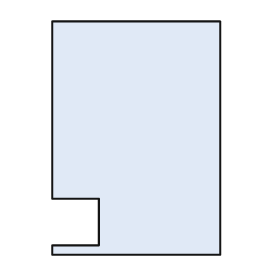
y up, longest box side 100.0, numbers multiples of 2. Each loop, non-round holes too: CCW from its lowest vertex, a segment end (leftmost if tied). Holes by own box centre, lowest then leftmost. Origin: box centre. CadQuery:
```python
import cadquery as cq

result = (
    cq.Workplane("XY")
    .moveTo(-36.0, -50.0)
    .lineTo(36.0, -50.0)
    .lineTo(36.0, 50.0)
    .lineTo(-36.0, 50.0)
    .lineTo(-36.0, -26.0)
    .lineTo(-16.0, -26.0)
    .lineTo(-16.0, -46.0)
    .lineTo(-36.0, -46.0)
    .close()
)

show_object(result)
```